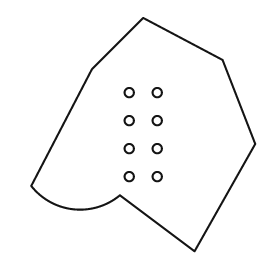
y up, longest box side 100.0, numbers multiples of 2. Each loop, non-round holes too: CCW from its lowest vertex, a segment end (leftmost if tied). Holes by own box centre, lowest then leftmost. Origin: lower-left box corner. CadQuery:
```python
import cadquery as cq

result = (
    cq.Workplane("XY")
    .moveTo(70.0, 0.0)
    .lineTo(96.0, 46.0)
    .lineTo(82.0, 82.0)
    .lineTo(48.0, 100.0)
    .lineTo(26.0, 78.0)
    .lineTo(0.0, 28.0)
    .threePointArc((18.0, 18.0), (38.0, 24.0))
    .close()
    .moveTo(42.0, 32.0)
    .circle(2.0)
    .moveTo(54.0, 32.0)
    .circle(2.0)
    .moveTo(42.0, 44.0)
    .circle(2.0)
    .moveTo(54.0, 44.0)
    .circle(2.0)
    .moveTo(42.0, 56.0)
    .circle(2.0)
    .moveTo(54.0, 56.0)
    .circle(2.0)
    .moveTo(42.0, 68.0)
    .circle(2.0)
    .moveTo(54.0, 68.0)
    .circle(2.0)
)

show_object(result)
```